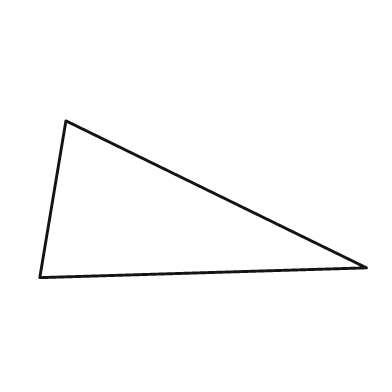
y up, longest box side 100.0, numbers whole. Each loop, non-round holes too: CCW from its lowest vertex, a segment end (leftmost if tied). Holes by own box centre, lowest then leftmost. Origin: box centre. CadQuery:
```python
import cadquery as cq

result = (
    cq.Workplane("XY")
    .moveTo(-50.0, -24.0)
    .lineTo(50.0, -21.0)
    .lineTo(-42.0, 24.0)
    .close()
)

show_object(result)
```